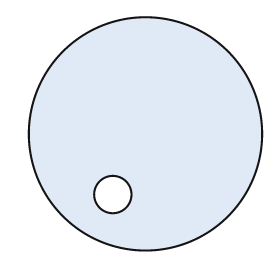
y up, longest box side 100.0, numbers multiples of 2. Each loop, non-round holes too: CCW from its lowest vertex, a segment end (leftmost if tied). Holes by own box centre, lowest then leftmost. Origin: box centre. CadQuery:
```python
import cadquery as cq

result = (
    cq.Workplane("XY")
    .moveTo(0.0, 0.0)
    .circle(50.0)
    .moveTo(-14.0, -26.0)
    .circle(8.0)
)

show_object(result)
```